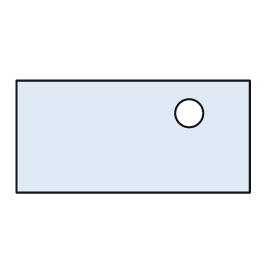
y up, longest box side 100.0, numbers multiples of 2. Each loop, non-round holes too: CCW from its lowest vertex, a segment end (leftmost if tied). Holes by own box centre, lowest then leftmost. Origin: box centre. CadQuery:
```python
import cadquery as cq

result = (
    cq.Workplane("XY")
    .moveTo(-50.0, -24.0)
    .lineTo(50.0, -24.0)
    .lineTo(50.0, 24.0)
    .lineTo(-50.0, 24.0)
    .close()
    .moveTo(24.0, 10.0)
    .circle(6.0)
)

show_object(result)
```